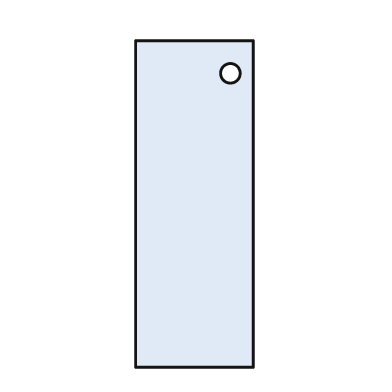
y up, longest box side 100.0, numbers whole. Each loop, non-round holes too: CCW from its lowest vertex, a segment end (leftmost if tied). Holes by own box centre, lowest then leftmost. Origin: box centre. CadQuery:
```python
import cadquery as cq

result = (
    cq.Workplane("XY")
    .moveTo(-18.0, -50.0)
    .lineTo(18.0, -50.0)
    .lineTo(18.0, 50.0)
    .lineTo(-18.0, 50.0)
    .close()
    .moveTo(11.0, 40.0)
    .circle(3.0)
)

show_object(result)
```